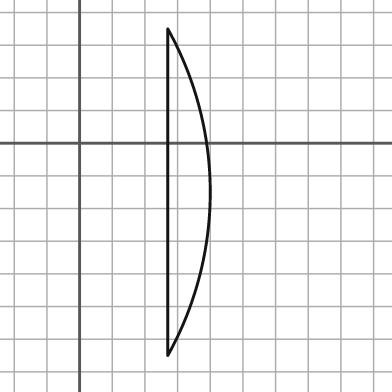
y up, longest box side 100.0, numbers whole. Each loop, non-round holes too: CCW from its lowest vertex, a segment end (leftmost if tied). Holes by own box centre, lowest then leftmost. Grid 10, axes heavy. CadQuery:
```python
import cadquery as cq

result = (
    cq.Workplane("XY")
    .moveTo(27.0, -65.0)
    .threePointArc((40.0, -15.0), (27.0, 35.0))
    .close()
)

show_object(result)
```